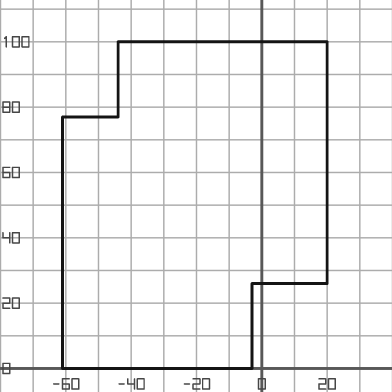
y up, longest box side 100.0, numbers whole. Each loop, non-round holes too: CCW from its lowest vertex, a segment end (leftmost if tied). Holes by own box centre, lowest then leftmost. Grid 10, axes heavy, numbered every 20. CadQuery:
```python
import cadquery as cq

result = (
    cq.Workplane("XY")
    .moveTo(-61.0, 0.0)
    .lineTo(-3.0, 0.0)
    .lineTo(-3.0, 26.0)
    .lineTo(20.0, 26.0)
    .lineTo(20.0, 100.0)
    .lineTo(-44.0, 100.0)
    .lineTo(-44.0, 77.0)
    .lineTo(-61.0, 77.0)
    .close()
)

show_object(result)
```